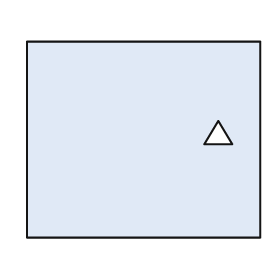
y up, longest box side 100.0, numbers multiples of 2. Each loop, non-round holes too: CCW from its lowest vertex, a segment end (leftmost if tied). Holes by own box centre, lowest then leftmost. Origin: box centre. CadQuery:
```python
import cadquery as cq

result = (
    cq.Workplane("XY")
    .moveTo(-50.0, -42.0)
    .lineTo(50.0, -42.0)
    .lineTo(50.0, 42.0)
    .lineTo(-50.0, 42.0)
    .close()
    .moveTo(26.0, -2.0)
    .lineTo(38.0, -2.0)
    .lineTo(32.0, 8.0)
    .close()
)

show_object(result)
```